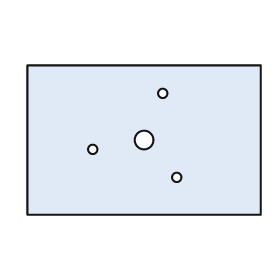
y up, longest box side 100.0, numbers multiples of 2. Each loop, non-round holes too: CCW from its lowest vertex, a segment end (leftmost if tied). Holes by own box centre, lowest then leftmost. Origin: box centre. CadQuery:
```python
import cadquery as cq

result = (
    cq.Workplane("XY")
    .moveTo(-50.0, -32.0)
    .lineTo(50.0, -32.0)
    .lineTo(50.0, 32.0)
    .lineTo(-50.0, 32.0)
    .close()
    .moveTo(14.0, -16.0)
    .circle(2.0)
    .moveTo(-22.0, -4.0)
    .circle(2.0)
    .moveTo(0.0, 0.0)
    .circle(4.0)
    .moveTo(8.0, 20.0)
    .circle(2.0)
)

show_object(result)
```